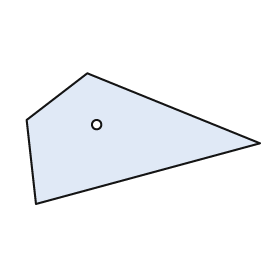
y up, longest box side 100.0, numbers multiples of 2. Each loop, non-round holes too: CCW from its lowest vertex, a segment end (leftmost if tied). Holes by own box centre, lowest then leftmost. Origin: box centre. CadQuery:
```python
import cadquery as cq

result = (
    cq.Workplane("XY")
    .moveTo(-46.0, -28.0)
    .lineTo(50.0, -2.0)
    .lineTo(-24.0, 28.0)
    .lineTo(-50.0, 8.0)
    .close()
    .moveTo(-20.0, 6.0)
    .circle(2.0)
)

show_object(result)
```